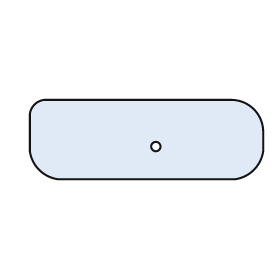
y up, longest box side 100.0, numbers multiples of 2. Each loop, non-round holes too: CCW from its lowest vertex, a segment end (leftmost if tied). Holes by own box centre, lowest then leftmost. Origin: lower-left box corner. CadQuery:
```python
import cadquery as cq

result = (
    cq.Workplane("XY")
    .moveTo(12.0, 0.0)
    .lineTo(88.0, 0.0)
    .threePointArc((96.0, 4.0), (100.0, 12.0))
    .lineTo(100.0, 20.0)
    .threePointArc((96.0, 30.0), (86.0, 34.0))
    .lineTo(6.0, 34.0)
    .threePointArc((2.0, 32.0), (0.0, 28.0))
    .lineTo(0.0, 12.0)
    .threePointArc((4.0, 4.0), (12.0, 0.0))
    .close()
    .moveTo(54.0, 14.0)
    .circle(2.0)
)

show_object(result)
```